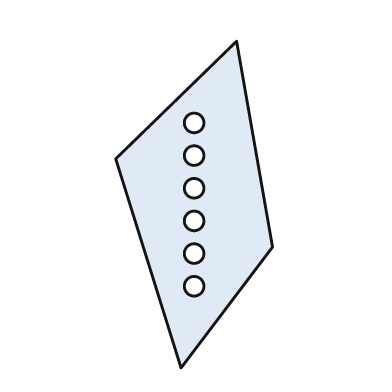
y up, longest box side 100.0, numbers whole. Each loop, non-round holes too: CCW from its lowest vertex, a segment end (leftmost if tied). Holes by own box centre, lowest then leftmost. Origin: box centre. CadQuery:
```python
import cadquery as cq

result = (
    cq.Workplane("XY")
    .moveTo(-4.0, -50.0)
    .lineTo(24.0, -13.0)
    .lineTo(13.0, 50.0)
    .lineTo(-24.0, 14.0)
    .close()
    .moveTo(0.0, -25.0)
    .circle(3.0)
    .moveTo(0.0, -15.0)
    .circle(3.0)
    .moveTo(0.0, -5.0)
    .circle(3.0)
    .moveTo(0.0, 5.0)
    .circle(3.0)
    .moveTo(0.0, 15.0)
    .circle(3.0)
    .moveTo(0.0, 25.0)
    .circle(3.0)
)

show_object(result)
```